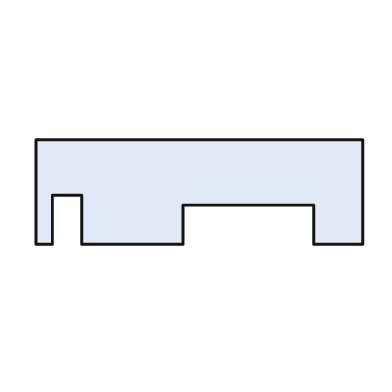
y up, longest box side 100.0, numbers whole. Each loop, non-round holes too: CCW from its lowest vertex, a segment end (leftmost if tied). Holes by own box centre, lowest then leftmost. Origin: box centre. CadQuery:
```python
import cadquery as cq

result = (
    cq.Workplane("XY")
    .moveTo(-50.0, -16.0)
    .lineTo(-45.0, -16.0)
    .lineTo(-45.0, -1.0)
    .lineTo(-36.0, -1.0)
    .lineTo(-36.0, -16.0)
    .lineTo(-5.0, -16.0)
    .lineTo(-5.0, -4.0)
    .lineTo(35.0, -4.0)
    .lineTo(35.0, -16.0)
    .lineTo(50.0, -16.0)
    .lineTo(50.0, 16.0)
    .lineTo(-50.0, 16.0)
    .close()
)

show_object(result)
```